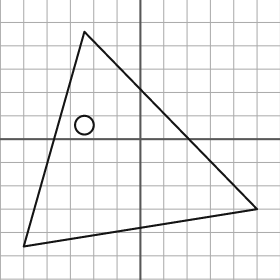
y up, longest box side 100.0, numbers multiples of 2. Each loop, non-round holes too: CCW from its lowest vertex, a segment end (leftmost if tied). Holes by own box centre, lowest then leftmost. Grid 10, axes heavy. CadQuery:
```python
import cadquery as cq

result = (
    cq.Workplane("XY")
    .moveTo(-50.0, -46.0)
    .lineTo(50.0, -30.0)
    .lineTo(-24.0, 46.0)
    .close()
    .moveTo(-24.0, 6.0)
    .circle(4.0)
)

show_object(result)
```